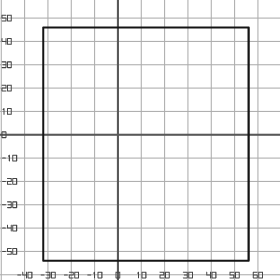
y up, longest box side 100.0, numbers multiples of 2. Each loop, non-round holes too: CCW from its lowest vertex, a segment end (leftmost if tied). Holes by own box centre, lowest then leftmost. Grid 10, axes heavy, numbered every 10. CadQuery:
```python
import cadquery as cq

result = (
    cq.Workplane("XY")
    .moveTo(-32.0, -54.0)
    .lineTo(56.0, -54.0)
    .lineTo(56.0, 46.0)
    .lineTo(-32.0, 46.0)
    .close()
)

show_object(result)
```